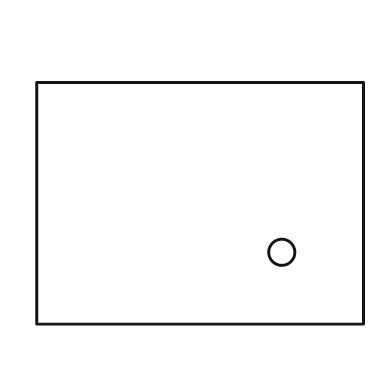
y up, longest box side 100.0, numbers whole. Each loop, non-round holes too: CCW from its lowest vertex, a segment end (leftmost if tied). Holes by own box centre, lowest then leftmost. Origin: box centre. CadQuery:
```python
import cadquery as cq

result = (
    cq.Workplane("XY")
    .moveTo(-50.0, -37.0)
    .lineTo(50.0, -37.0)
    .lineTo(50.0, 37.0)
    .lineTo(-50.0, 37.0)
    .close()
    .moveTo(25.0, -15.0)
    .circle(4.0)
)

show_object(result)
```